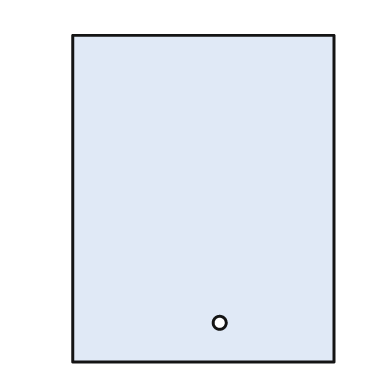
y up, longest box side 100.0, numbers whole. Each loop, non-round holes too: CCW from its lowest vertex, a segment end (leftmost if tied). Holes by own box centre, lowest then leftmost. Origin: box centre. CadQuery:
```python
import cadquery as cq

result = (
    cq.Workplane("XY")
    .moveTo(-40.0, -50.0)
    .lineTo(40.0, -50.0)
    .lineTo(40.0, 50.0)
    .lineTo(-40.0, 50.0)
    .close()
    .moveTo(5.0, -38.0)
    .circle(2.0)
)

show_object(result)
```